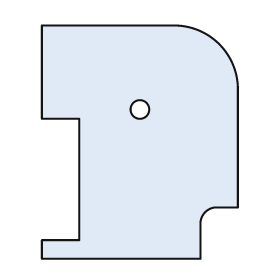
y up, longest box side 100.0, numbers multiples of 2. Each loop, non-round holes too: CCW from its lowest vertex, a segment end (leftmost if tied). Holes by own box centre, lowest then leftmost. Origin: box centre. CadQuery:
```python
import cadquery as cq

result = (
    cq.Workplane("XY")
    .moveTo(-42.0, -50.0)
    .lineTo(26.0, -50.0)
    .lineTo(26.0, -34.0)
    .threePointArc((28.0, -30.0), (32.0, -28.0))
    .lineTo(42.0, -28.0)
    .lineTo(42.0, 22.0)
    .threePointArc((34.0, 42.0), (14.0, 50.0))
    .lineTo(-42.0, 50.0)
    .lineTo(-42.0, 10.0)
    .lineTo(-26.0, 10.0)
    .lineTo(-26.0, -42.0)
    .lineTo(-42.0, -42.0)
    .close()
    .moveTo(0.0, 14.0)
    .circle(4.0)
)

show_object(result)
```